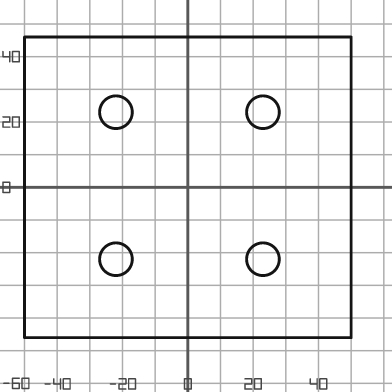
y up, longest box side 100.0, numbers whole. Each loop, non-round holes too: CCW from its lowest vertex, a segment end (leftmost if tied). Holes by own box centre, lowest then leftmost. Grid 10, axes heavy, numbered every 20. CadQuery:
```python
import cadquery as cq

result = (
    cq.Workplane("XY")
    .moveTo(-50.0, -46.0)
    .lineTo(50.0, -46.0)
    .lineTo(50.0, 46.0)
    .lineTo(-50.0, 46.0)
    .close()
    .moveTo(-22.0, -22.0)
    .circle(5.0)
    .moveTo(23.0, -22.0)
    .circle(5.0)
    .moveTo(-22.0, 23.0)
    .circle(5.0)
    .moveTo(23.0, 23.0)
    .circle(5.0)
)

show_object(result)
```